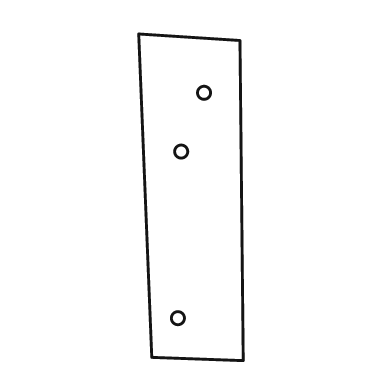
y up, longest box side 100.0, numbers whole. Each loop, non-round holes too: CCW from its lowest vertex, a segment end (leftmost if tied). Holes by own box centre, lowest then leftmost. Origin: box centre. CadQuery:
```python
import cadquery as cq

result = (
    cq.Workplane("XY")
    .moveTo(16.0, -50.0)
    .lineTo(15.0, 48.0)
    .lineTo(-16.0, 50.0)
    .lineTo(-12.0, -49.0)
    .close()
    .moveTo(-4.0, -37.0)
    .circle(2.0)
    .moveTo(-3.0, 14.0)
    .circle(2.0)
    .moveTo(4.0, 32.0)
    .circle(2.0)
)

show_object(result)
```